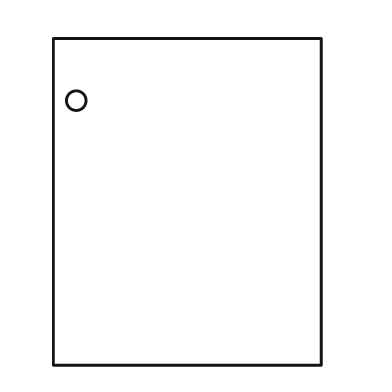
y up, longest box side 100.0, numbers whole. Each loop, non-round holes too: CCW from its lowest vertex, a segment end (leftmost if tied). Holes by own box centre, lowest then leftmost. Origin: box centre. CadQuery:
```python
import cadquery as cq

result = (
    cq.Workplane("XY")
    .moveTo(-41.0, -50.0)
    .lineTo(41.0, -50.0)
    .lineTo(41.0, 50.0)
    .lineTo(-41.0, 50.0)
    .close()
    .moveTo(-34.0, 31.0)
    .circle(3.0)
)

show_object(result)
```